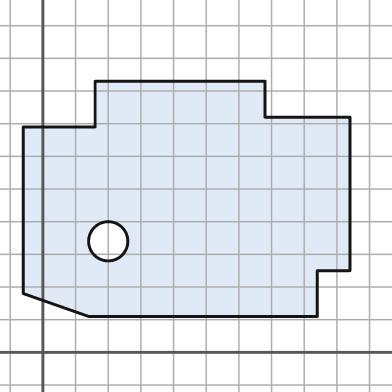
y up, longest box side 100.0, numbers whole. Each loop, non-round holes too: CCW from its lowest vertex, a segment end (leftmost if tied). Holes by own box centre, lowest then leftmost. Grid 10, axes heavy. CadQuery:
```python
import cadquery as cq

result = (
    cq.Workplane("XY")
    .moveTo(14.0, 11.0)
    .lineTo(84.0, 11.0)
    .lineTo(84.0, 25.0)
    .lineTo(94.0, 25.0)
    .lineTo(94.0, 72.0)
    .lineTo(68.0, 72.0)
    .lineTo(68.0, 83.0)
    .lineTo(16.0, 83.0)
    .lineTo(16.0, 69.0)
    .lineTo(-6.0, 69.0)
    .lineTo(-6.0, 18.0)
    .close()
    .moveTo(20.0, 34.0)
    .circle(6.0)
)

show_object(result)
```